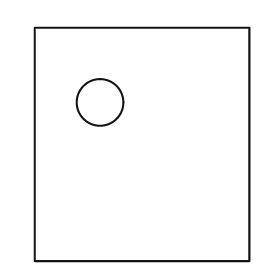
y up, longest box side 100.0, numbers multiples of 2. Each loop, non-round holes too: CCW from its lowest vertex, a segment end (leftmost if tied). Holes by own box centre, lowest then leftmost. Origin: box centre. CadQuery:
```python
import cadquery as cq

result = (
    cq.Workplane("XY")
    .moveTo(-46.0, -50.0)
    .lineTo(46.0, -50.0)
    .lineTo(46.0, 50.0)
    .lineTo(-46.0, 50.0)
    .close()
    .moveTo(-18.0, 18.0)
    .circle(10.0)
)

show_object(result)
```